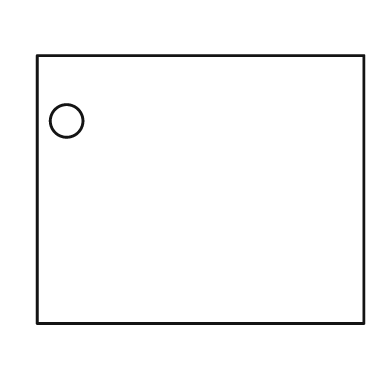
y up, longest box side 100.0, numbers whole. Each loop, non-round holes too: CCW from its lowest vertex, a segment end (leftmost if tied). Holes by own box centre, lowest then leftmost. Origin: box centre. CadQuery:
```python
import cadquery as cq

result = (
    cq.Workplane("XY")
    .moveTo(-50.0, -41.0)
    .lineTo(50.0, -41.0)
    .lineTo(50.0, 41.0)
    .lineTo(-50.0, 41.0)
    .close()
    .moveTo(-41.0, 21.0)
    .circle(5.0)
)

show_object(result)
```